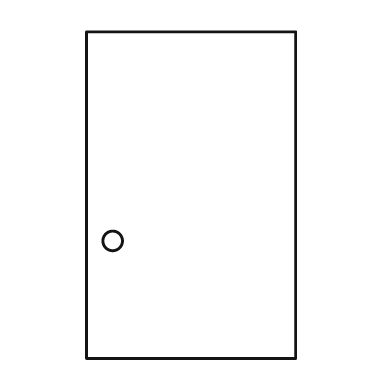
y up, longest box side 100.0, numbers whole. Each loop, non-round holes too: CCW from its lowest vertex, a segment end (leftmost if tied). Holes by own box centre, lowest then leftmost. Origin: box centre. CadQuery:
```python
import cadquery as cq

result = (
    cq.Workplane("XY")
    .moveTo(-32.0, -50.0)
    .lineTo(32.0, -50.0)
    .lineTo(32.0, 50.0)
    .lineTo(-32.0, 50.0)
    .close()
    .moveTo(-24.0, -14.0)
    .circle(3.0)
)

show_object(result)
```